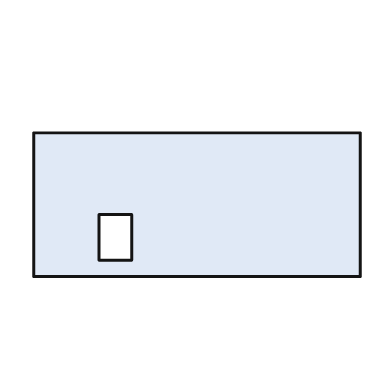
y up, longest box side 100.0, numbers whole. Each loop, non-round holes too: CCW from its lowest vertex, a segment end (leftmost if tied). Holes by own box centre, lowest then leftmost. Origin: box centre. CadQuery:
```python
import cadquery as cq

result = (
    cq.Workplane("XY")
    .moveTo(-50.0, -22.0)
    .lineTo(50.0, -22.0)
    .lineTo(50.0, 22.0)
    .lineTo(-50.0, 22.0)
    .close()
    .moveTo(-30.0, -17.0)
    .lineTo(-20.0, -17.0)
    .lineTo(-20.0, -3.0)
    .lineTo(-30.0, -3.0)
    .close()
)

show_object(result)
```